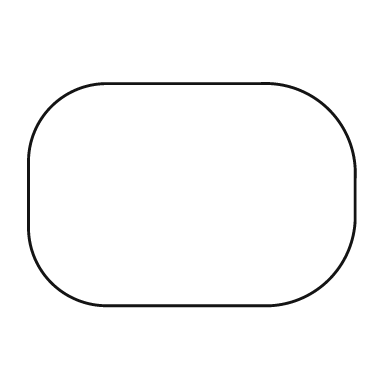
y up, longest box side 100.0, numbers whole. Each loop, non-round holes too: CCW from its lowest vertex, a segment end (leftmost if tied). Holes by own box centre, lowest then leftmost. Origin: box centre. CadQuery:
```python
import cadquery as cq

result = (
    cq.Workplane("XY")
    .moveTo(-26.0, -34.0)
    .lineTo(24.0, -34.0)
    .threePointArc((42.0, -26.0), (50.0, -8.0))
    .lineTo(50.0, 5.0)
    .threePointArc((42.0, 26.0), (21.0, 34.0))
    .lineTo(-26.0, 34.0)
    .threePointArc((-43.0, 27.0), (-50.0, 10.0))
    .lineTo(-50.0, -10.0)
    .threePointArc((-43.0, -27.0), (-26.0, -34.0))
    .close()
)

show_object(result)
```